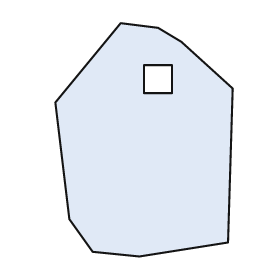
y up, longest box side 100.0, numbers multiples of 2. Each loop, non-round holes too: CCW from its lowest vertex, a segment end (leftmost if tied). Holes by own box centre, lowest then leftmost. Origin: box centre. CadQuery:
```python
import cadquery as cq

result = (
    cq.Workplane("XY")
    .moveTo(-2.0, -50.0)
    .lineTo(36.0, -44.0)
    .lineTo(38.0, 22.0)
    .lineTo(16.0, 42.0)
    .lineTo(6.0, 48.0)
    .lineTo(-10.0, 50.0)
    .lineTo(-38.0, 16.0)
    .lineTo(-32.0, -34.0)
    .lineTo(-22.0, -48.0)
    .close()
    .moveTo(0.0, 20.0)
    .lineTo(12.0, 20.0)
    .lineTo(12.0, 32.0)
    .lineTo(0.0, 32.0)
    .close()
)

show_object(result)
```